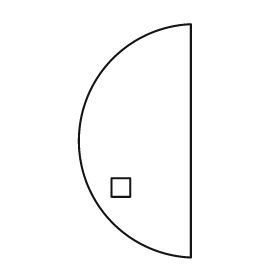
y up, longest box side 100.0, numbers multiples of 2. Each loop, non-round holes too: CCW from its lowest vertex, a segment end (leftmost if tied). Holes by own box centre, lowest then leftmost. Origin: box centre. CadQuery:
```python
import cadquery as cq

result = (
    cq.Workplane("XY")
    .moveTo(24.0, -50.0)
    .lineTo(24.0, 50.0)
    .threePointArc((-24.0, 0.0), (24.0, -50.0))
    .close()
    .moveTo(-10.0, -24.0)
    .lineTo(-2.0, -24.0)
    .lineTo(-2.0, -16.0)
    .lineTo(-10.0, -16.0)
    .close()
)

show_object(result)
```